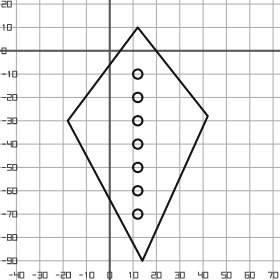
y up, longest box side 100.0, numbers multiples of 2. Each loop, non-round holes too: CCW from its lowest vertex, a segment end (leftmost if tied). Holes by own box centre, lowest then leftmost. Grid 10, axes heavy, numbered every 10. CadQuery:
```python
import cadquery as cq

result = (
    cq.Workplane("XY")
    .moveTo(14.0, -90.0)
    .lineTo(42.0, -28.0)
    .lineTo(12.0, 10.0)
    .lineTo(-18.0, -30.0)
    .close()
    .moveTo(12.0, -70.0)
    .circle(2.0)
    .moveTo(12.0, -60.0)
    .circle(2.0)
    .moveTo(12.0, -50.0)
    .circle(2.0)
    .moveTo(12.0, -40.0)
    .circle(2.0)
    .moveTo(12.0, -30.0)
    .circle(2.0)
    .moveTo(12.0, -20.0)
    .circle(2.0)
    .moveTo(12.0, -10.0)
    .circle(2.0)
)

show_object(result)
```